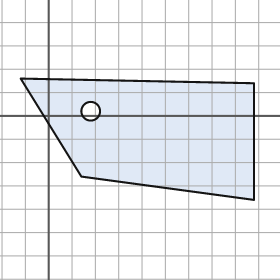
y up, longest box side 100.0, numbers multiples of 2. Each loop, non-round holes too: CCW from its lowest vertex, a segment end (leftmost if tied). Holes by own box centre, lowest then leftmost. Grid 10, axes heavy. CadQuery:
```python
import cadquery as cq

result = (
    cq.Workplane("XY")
    .moveTo(88.0, -36.0)
    .lineTo(88.0, 14.0)
    .lineTo(-12.0, 16.0)
    .lineTo(14.0, -26.0)
    .close()
    .moveTo(18.0, 2.0)
    .circle(4.0)
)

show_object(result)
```